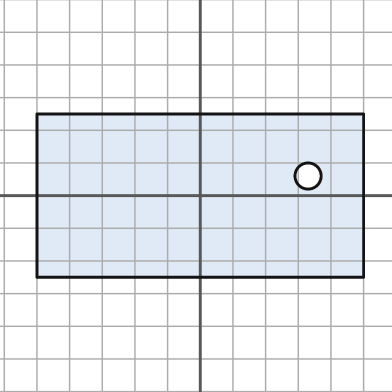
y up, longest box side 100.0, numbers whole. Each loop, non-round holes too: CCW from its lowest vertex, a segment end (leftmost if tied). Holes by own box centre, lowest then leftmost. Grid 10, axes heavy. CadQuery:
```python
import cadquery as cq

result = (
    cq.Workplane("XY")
    .moveTo(-50.0, -25.0)
    .lineTo(50.0, -25.0)
    .lineTo(50.0, 25.0)
    .lineTo(-50.0, 25.0)
    .close()
    .moveTo(33.0, 6.0)
    .circle(4.0)
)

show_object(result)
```